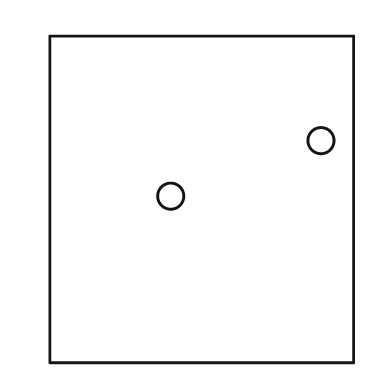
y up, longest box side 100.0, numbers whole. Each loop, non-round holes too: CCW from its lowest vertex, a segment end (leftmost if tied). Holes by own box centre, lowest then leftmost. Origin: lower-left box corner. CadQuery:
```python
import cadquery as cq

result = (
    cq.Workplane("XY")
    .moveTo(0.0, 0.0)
    .lineTo(93.0, 0.0)
    .lineTo(93.0, 100.0)
    .lineTo(0.0, 100.0)
    .close()
    .moveTo(37.0, 51.0)
    .circle(4.0)
    .moveTo(83.0, 68.0)
    .circle(4.0)
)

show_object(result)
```